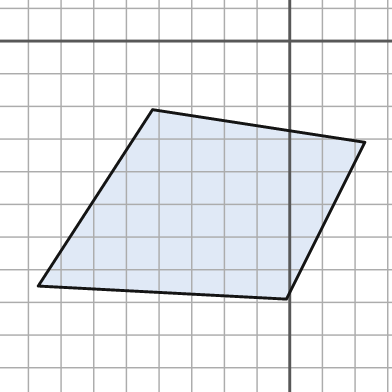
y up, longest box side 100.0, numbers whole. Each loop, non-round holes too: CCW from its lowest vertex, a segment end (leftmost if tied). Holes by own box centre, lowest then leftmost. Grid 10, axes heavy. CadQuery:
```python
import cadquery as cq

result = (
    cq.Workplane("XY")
    .moveTo(-1.0, -79.0)
    .lineTo(23.0, -31.0)
    .lineTo(-42.0, -21.0)
    .lineTo(-77.0, -75.0)
    .close()
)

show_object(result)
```